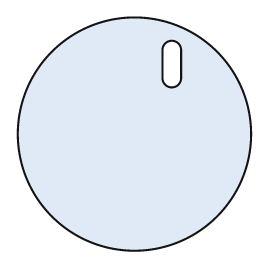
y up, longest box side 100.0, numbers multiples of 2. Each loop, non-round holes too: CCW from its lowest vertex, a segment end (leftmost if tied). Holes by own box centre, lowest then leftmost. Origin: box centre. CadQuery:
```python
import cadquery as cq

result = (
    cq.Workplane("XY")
    .moveTo(0.0, 0.0)
    .circle(50.0)
    .moveTo(12.0, 24.0)
    .threePointArc((16.0, 20.0), (20.0, 24.0))
    .lineTo(20.0, 36.0)
    .threePointArc((16.0, 40.0), (12.0, 36.0))
    .close()
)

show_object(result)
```